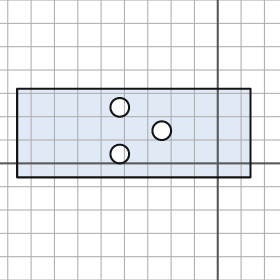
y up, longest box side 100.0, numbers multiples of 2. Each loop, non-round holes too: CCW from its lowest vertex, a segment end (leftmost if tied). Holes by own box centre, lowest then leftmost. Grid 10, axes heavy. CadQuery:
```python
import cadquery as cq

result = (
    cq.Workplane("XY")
    .moveTo(-86.0, -6.0)
    .lineTo(14.0, -6.0)
    .lineTo(14.0, 32.0)
    .lineTo(-86.0, 32.0)
    .close()
    .moveTo(-42.0, 4.0)
    .circle(4.0)
    .moveTo(-24.0, 14.0)
    .circle(4.0)
    .moveTo(-42.0, 24.0)
    .circle(4.0)
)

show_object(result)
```